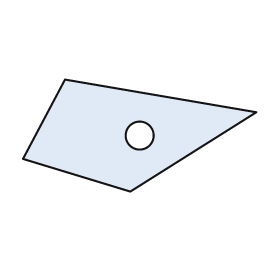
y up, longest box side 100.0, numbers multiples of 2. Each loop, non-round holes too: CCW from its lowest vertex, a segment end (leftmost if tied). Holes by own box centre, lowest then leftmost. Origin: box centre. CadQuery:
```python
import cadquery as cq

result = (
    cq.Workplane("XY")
    .moveTo(-4.0, -24.0)
    .lineTo(50.0, 10.0)
    .lineTo(-32.0, 24.0)
    .lineTo(-50.0, -10.0)
    .close()
    .moveTo(0.0, 0.0)
    .circle(6.0)
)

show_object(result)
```